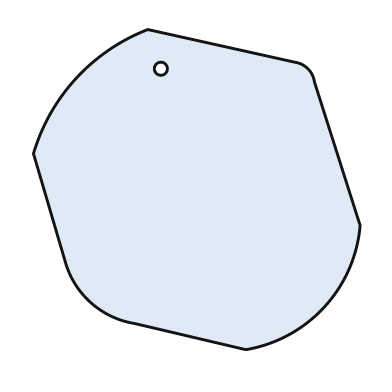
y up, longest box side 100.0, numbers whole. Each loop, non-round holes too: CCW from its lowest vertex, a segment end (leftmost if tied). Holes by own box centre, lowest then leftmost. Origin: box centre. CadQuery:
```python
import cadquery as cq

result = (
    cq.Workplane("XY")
    .moveTo(15.0, -49.0)
    .threePointArc((39.0, -36.0), (50.0, -11.0))
    .lineTo(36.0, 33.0)
    .threePointArc((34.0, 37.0), (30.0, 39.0))
    .lineTo(-15.0, 49.0)
    .threePointArc((-37.0, 34.0), (-50.0, 11.0))
    .lineTo(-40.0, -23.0)
    .threePointArc((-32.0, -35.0), (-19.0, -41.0))
    .close()
    .moveTo(-11.0, 37.0)
    .circle(2.0)
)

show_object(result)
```